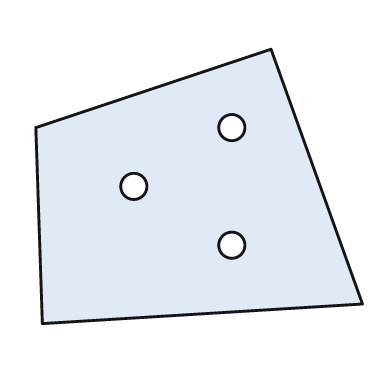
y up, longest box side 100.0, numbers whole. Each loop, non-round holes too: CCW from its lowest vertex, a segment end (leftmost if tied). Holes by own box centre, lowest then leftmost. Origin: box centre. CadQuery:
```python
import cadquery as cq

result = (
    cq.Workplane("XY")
    .moveTo(-48.0, -42.0)
    .lineTo(50.0, -36.0)
    .lineTo(22.0, 42.0)
    .lineTo(-50.0, 18.0)
    .close()
    .moveTo(10.0, -18.0)
    .circle(4.0)
    .moveTo(-20.0, 0.0)
    .circle(4.0)
    .moveTo(10.0, 18.0)
    .circle(4.0)
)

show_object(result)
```